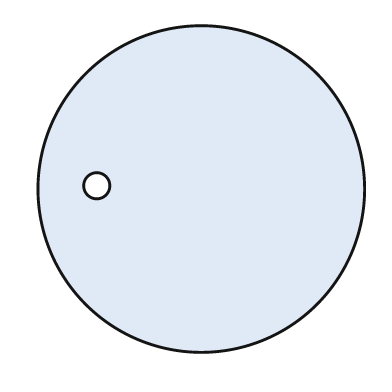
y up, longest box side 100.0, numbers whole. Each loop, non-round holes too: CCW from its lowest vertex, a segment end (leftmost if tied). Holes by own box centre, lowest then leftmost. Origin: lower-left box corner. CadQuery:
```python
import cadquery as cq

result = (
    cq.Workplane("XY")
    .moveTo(50.0, 50.0)
    .circle(50.0)
    .moveTo(18.0, 51.0)
    .circle(4.0)
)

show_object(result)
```